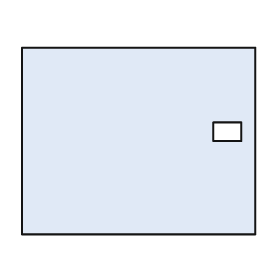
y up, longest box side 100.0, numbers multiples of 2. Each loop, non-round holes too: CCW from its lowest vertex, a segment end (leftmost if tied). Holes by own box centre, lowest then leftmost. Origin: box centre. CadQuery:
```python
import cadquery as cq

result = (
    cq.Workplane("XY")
    .moveTo(-50.0, -40.0)
    .lineTo(50.0, -40.0)
    .lineTo(50.0, 40.0)
    .lineTo(-50.0, 40.0)
    .close()
    .moveTo(32.0, 0.0)
    .lineTo(44.0, 0.0)
    .lineTo(44.0, 8.0)
    .lineTo(32.0, 8.0)
    .close()
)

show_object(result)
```